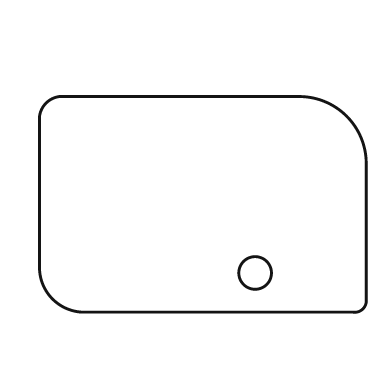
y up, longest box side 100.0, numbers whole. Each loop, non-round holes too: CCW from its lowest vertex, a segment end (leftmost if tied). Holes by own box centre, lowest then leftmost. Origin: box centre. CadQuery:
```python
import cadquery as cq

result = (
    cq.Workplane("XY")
    .moveTo(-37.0, -33.0)
    .lineTo(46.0, -33.0)
    .threePointArc((49.0, -32.0), (50.0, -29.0))
    .lineTo(50.0, 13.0)
    .threePointArc((44.0, 27.0), (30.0, 33.0))
    .lineTo(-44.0, 33.0)
    .threePointArc((-48.0, 31.0), (-50.0, 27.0))
    .lineTo(-50.0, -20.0)
    .threePointArc((-46.0, -29.0), (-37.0, -33.0))
    .close()
    .moveTo(16.0, -21.0)
    .circle(5.0)
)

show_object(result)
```